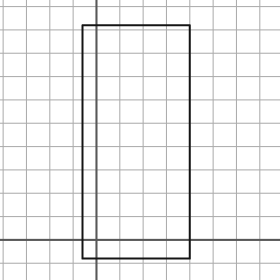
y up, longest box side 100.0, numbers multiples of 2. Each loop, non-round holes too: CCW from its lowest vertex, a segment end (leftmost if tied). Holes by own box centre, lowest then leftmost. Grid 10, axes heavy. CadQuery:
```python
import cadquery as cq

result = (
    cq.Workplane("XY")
    .moveTo(-6.0, -8.0)
    .lineTo(40.0, -8.0)
    .lineTo(40.0, 92.0)
    .lineTo(-6.0, 92.0)
    .close()
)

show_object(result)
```